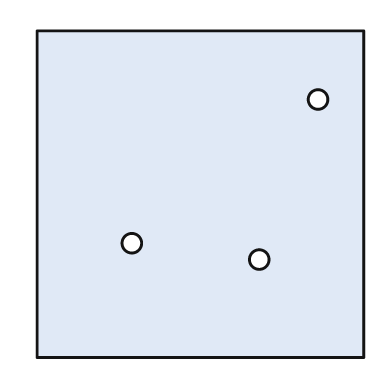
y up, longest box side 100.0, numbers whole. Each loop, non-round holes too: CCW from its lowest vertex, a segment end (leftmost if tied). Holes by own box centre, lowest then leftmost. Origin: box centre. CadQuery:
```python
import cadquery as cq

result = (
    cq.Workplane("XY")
    .moveTo(-50.0, -50.0)
    .lineTo(50.0, -50.0)
    .lineTo(50.0, 50.0)
    .lineTo(-50.0, 50.0)
    .close()
    .moveTo(18.0, -20.0)
    .circle(3.0)
    .moveTo(-21.0, -15.0)
    .circle(3.0)
    .moveTo(36.0, 29.0)
    .circle(3.0)
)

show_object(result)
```